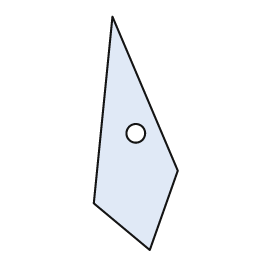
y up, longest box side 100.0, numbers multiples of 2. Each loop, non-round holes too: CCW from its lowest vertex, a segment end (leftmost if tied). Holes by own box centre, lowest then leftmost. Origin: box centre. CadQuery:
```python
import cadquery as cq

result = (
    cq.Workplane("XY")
    .moveTo(6.0, -50.0)
    .lineTo(18.0, -16.0)
    .lineTo(-10.0, 50.0)
    .lineTo(-18.0, -30.0)
    .close()
    .moveTo(0.0, 0.0)
    .circle(4.0)
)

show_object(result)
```